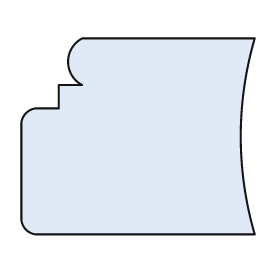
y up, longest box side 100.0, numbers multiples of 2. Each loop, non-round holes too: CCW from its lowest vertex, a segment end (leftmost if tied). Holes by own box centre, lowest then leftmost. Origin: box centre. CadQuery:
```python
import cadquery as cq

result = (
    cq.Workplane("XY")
    .moveTo(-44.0, -42.0)
    .lineTo(50.0, -42.0)
    .threePointArc((44.0, 0.0), (50.0, 42.0))
    .lineTo(-24.0, 42.0)
    .threePointArc((-30.0, 32.0), (-24.0, 22.0))
    .lineTo(-34.0, 22.0)
    .lineTo(-34.0, 12.0)
    .lineTo(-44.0, 12.0)
    .threePointArc((-48.0, 10.0), (-50.0, 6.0))
    .lineTo(-50.0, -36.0)
    .threePointArc((-48.0, -40.0), (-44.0, -42.0))
    .close()
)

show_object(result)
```